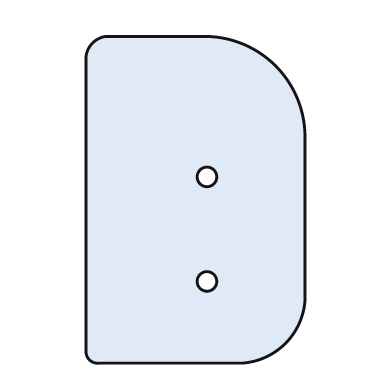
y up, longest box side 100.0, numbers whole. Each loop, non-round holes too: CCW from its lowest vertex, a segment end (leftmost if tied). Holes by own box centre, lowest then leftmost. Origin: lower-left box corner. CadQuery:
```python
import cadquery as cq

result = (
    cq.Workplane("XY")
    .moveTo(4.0, 0.0)
    .lineTo(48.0, 0.0)
    .threePointArc((61.0, 6.0), (67.0, 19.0))
    .lineTo(67.0, 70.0)
    .threePointArc((58.0, 91.0), (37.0, 100.0))
    .lineTo(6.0, 100.0)
    .threePointArc((2.0, 98.0), (0.0, 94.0))
    .lineTo(0.0, 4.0)
    .threePointArc((1.0, 1.0), (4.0, 0.0))
    .close()
    .moveTo(37.0, 25.0)
    .circle(3.0)
    .moveTo(37.0, 57.0)
    .circle(3.0)
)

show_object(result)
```